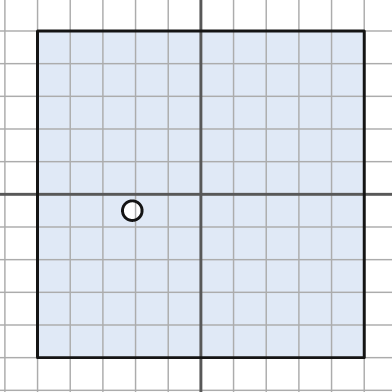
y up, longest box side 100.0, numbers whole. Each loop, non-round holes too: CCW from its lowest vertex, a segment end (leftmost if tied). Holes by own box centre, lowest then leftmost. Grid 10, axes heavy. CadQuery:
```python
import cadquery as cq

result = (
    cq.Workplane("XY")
    .moveTo(-50.0, -50.0)
    .lineTo(50.0, -50.0)
    .lineTo(50.0, 50.0)
    .lineTo(-50.0, 50.0)
    .close()
    .moveTo(-21.0, -5.0)
    .circle(3.0)
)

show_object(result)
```